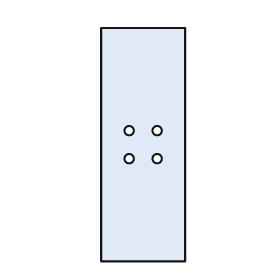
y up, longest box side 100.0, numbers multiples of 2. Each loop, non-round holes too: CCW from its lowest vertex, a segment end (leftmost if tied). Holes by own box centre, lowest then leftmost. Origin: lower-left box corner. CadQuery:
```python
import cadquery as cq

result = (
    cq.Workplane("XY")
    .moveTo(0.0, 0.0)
    .lineTo(36.0, 0.0)
    .lineTo(36.0, 100.0)
    .lineTo(0.0, 100.0)
    .close()
    .moveTo(12.0, 44.0)
    .circle(2.0)
    .moveTo(24.0, 44.0)
    .circle(2.0)
    .moveTo(12.0, 56.0)
    .circle(2.0)
    .moveTo(24.0, 56.0)
    .circle(2.0)
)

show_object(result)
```